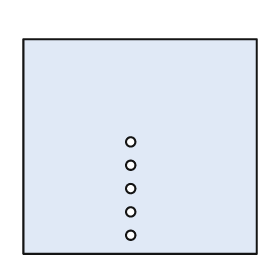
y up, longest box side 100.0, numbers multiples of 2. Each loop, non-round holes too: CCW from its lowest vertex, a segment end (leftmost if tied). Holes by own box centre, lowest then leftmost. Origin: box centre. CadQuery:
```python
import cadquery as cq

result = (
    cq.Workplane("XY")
    .moveTo(-50.0, -46.0)
    .lineTo(50.0, -46.0)
    .lineTo(50.0, 46.0)
    .lineTo(-50.0, 46.0)
    .close()
    .moveTo(-4.0, -38.0)
    .circle(2.0)
    .moveTo(-4.0, -28.0)
    .circle(2.0)
    .moveTo(-4.0, -18.0)
    .circle(2.0)
    .moveTo(-4.0, -8.0)
    .circle(2.0)
    .moveTo(-4.0, 2.0)
    .circle(2.0)
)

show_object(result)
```